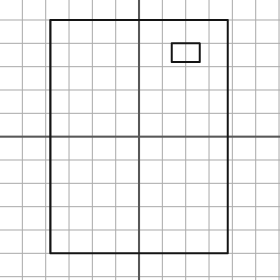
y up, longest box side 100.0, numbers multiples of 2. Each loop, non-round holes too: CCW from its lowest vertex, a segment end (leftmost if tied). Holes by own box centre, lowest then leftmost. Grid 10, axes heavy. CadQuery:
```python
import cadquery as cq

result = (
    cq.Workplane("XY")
    .moveTo(-38.0, -50.0)
    .lineTo(38.0, -50.0)
    .lineTo(38.0, 50.0)
    .lineTo(-38.0, 50.0)
    .close()
    .moveTo(14.0, 32.0)
    .lineTo(26.0, 32.0)
    .lineTo(26.0, 40.0)
    .lineTo(14.0, 40.0)
    .close()
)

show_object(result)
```